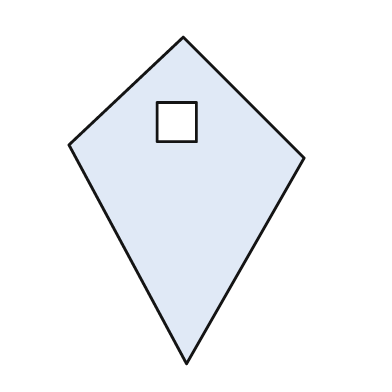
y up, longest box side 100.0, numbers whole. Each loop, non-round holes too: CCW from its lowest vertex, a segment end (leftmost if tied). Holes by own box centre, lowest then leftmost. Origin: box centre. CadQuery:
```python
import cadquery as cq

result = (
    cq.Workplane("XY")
    .moveTo(0.0, -50.0)
    .lineTo(36.0, 13.0)
    .lineTo(-1.0, 50.0)
    .lineTo(-36.0, 17.0)
    .close()
    .moveTo(-9.0, 18.0)
    .lineTo(3.0, 18.0)
    .lineTo(3.0, 30.0)
    .lineTo(-9.0, 30.0)
    .close()
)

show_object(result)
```